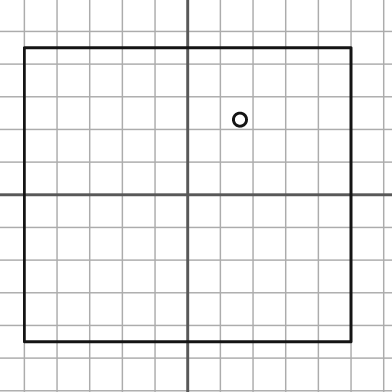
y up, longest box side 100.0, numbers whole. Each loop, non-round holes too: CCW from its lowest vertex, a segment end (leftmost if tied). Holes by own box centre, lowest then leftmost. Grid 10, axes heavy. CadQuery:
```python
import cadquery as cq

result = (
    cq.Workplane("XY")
    .moveTo(-50.0, -45.0)
    .lineTo(50.0, -45.0)
    .lineTo(50.0, 45.0)
    .lineTo(-50.0, 45.0)
    .close()
    .moveTo(16.0, 23.0)
    .circle(2.0)
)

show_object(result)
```